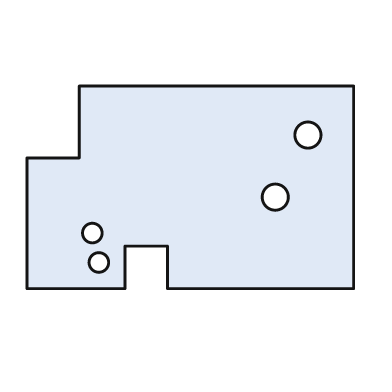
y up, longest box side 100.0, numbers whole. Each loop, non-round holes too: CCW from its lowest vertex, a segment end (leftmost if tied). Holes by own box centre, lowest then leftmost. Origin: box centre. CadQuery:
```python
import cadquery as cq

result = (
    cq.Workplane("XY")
    .moveTo(-50.0, -31.0)
    .lineTo(-20.0, -31.0)
    .lineTo(-20.0, -18.0)
    .lineTo(-7.0, -18.0)
    .lineTo(-7.0, -31.0)
    .lineTo(50.0, -31.0)
    .lineTo(50.0, 31.0)
    .lineTo(-34.0, 31.0)
    .lineTo(-34.0, 9.0)
    .lineTo(-50.0, 9.0)
    .close()
    .moveTo(-28.0, -23.0)
    .circle(3.0)
    .moveTo(-30.0, -14.0)
    .circle(3.0)
    .moveTo(26.0, -3.0)
    .circle(4.0)
    .moveTo(36.0, 16.0)
    .circle(4.0)
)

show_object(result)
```